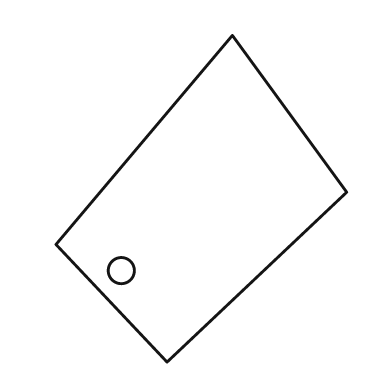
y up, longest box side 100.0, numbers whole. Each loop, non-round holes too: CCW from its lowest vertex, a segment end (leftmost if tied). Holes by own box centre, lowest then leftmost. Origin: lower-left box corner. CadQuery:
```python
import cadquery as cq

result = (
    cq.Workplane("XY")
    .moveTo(34.0, 0.0)
    .lineTo(89.0, 52.0)
    .lineTo(54.0, 100.0)
    .lineTo(0.0, 36.0)
    .close()
    .moveTo(20.0, 28.0)
    .circle(4.0)
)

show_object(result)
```